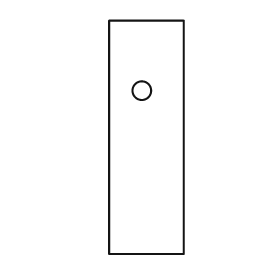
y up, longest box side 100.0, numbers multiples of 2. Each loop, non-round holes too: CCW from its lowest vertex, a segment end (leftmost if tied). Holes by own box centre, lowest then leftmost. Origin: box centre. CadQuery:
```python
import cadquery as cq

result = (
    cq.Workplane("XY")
    .moveTo(-16.0, -50.0)
    .lineTo(16.0, -50.0)
    .lineTo(16.0, 50.0)
    .lineTo(-16.0, 50.0)
    .close()
    .moveTo(-2.0, 20.0)
    .circle(4.0)
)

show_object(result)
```